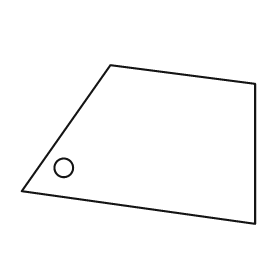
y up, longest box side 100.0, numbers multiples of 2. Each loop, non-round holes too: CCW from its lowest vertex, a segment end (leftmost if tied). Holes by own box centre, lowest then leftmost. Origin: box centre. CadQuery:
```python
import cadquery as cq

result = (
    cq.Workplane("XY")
    .moveTo(50.0, -34.0)
    .lineTo(50.0, 26.0)
    .lineTo(-12.0, 34.0)
    .lineTo(-50.0, -20.0)
    .close()
    .moveTo(-32.0, -10.0)
    .circle(4.0)
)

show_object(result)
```